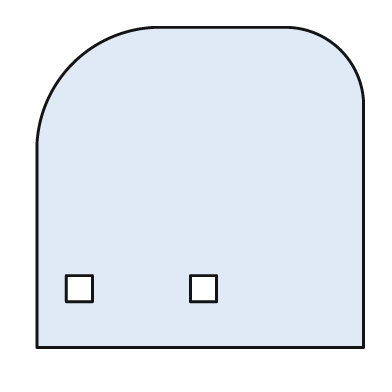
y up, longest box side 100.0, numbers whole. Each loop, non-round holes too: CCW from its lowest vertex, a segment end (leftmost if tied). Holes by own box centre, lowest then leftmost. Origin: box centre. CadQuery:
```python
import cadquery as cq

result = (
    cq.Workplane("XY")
    .moveTo(-50.0, -49.0)
    .lineTo(50.0, -49.0)
    .lineTo(50.0, 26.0)
    .threePointArc((43.0, 42.0), (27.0, 49.0))
    .lineTo(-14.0, 49.0)
    .threePointArc((-39.0, 38.0), (-50.0, 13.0))
    .close()
    .moveTo(-41.0, -35.0)
    .lineTo(-33.0, -35.0)
    .lineTo(-33.0, -27.0)
    .lineTo(-41.0, -27.0)
    .close()
    .moveTo(-3.0, -35.0)
    .lineTo(5.0, -35.0)
    .lineTo(5.0, -27.0)
    .lineTo(-3.0, -27.0)
    .close()
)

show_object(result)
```